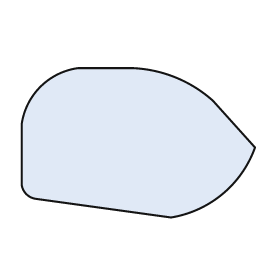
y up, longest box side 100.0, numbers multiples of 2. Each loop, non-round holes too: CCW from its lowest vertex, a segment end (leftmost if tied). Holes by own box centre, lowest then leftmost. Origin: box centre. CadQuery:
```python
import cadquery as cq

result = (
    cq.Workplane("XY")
    .moveTo(14.0, -32.0)
    .threePointArc((36.0, -22.0), (50.0, -2.0))
    .lineTo(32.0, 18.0)
    .threePointArc((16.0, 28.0), (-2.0, 32.0))
    .lineTo(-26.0, 32.0)
    .threePointArc((-42.0, 24.0), (-50.0, 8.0))
    .lineTo(-50.0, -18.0)
    .threePointArc((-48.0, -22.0), (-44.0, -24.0))
    .close()
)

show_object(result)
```